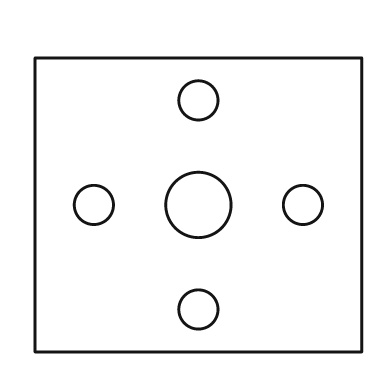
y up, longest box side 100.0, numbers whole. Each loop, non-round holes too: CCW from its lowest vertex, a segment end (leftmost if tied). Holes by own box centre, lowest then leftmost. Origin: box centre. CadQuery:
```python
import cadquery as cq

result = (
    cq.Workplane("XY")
    .moveTo(-50.0, -45.0)
    .lineTo(50.0, -45.0)
    .lineTo(50.0, 45.0)
    .lineTo(-50.0, 45.0)
    .close()
    .moveTo(0.0, -32.0)
    .circle(6.0)
    .moveTo(-32.0, 0.0)
    .circle(6.0)
    .moveTo(0.0, 0.0)
    .circle(10.0)
    .moveTo(32.0, 0.0)
    .circle(6.0)
    .moveTo(0.0, 32.0)
    .circle(6.0)
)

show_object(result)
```